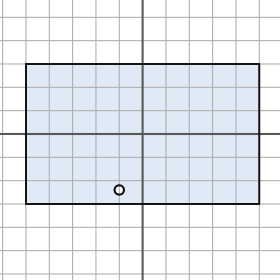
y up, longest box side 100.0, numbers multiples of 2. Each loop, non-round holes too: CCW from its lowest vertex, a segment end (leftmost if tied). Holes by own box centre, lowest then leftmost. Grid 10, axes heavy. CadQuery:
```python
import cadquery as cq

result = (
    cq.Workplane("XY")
    .moveTo(-50.0, -30.0)
    .lineTo(50.0, -30.0)
    .lineTo(50.0, 30.0)
    .lineTo(-50.0, 30.0)
    .close()
    .moveTo(-10.0, -24.0)
    .circle(2.0)
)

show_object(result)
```